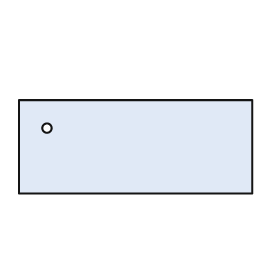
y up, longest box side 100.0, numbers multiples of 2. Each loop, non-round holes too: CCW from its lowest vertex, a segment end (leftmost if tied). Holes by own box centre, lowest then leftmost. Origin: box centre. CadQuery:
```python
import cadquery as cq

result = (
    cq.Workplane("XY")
    .moveTo(-50.0, -20.0)
    .lineTo(50.0, -20.0)
    .lineTo(50.0, 20.0)
    .lineTo(-50.0, 20.0)
    .close()
    .moveTo(-38.0, 8.0)
    .circle(2.0)
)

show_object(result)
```